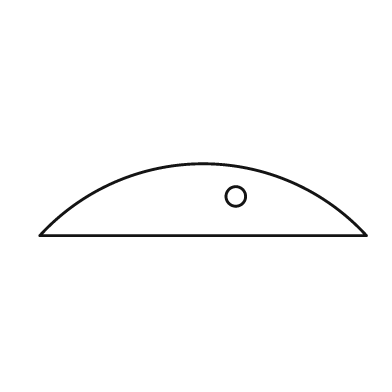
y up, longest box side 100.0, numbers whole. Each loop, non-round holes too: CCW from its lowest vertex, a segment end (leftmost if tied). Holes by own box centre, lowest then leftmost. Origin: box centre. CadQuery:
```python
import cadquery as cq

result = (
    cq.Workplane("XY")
    .moveTo(-50.0, -11.0)
    .lineTo(50.0, -11.0)
    .threePointArc((0.0, 11.0), (-50.0, -11.0))
    .close()
    .moveTo(10.0, 1.0)
    .circle(3.0)
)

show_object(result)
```